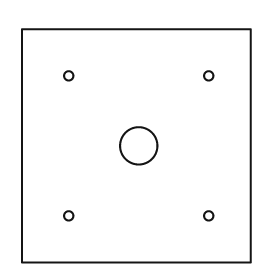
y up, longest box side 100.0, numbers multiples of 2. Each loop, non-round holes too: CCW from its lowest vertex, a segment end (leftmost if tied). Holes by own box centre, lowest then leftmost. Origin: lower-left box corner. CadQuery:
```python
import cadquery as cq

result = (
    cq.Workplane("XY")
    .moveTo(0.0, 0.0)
    .lineTo(98.0, 0.0)
    .lineTo(98.0, 100.0)
    .lineTo(0.0, 100.0)
    .close()
    .moveTo(20.0, 20.0)
    .circle(2.0)
    .moveTo(80.0, 20.0)
    .circle(2.0)
    .moveTo(50.0, 50.0)
    .circle(8.0)
    .moveTo(20.0, 80.0)
    .circle(2.0)
    .moveTo(80.0, 80.0)
    .circle(2.0)
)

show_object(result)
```